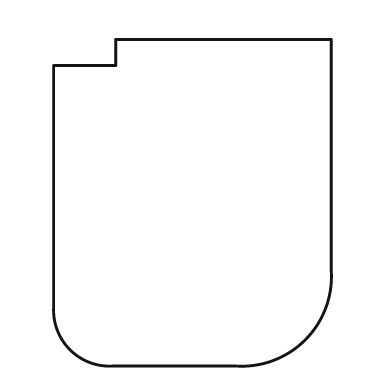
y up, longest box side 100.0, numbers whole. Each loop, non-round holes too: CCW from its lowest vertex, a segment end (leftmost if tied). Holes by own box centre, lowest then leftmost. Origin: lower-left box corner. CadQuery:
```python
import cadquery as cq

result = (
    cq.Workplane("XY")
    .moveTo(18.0, 0.0)
    .lineTo(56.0, 0.0)
    .threePointArc((77.0, 8.0), (85.0, 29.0))
    .lineTo(85.0, 100.0)
    .lineTo(19.0, 100.0)
    .lineTo(19.0, 92.0)
    .lineTo(0.0, 92.0)
    .lineTo(0.0, 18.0)
    .threePointArc((5.0, 5.0), (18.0, 0.0))
    .close()
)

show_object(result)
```